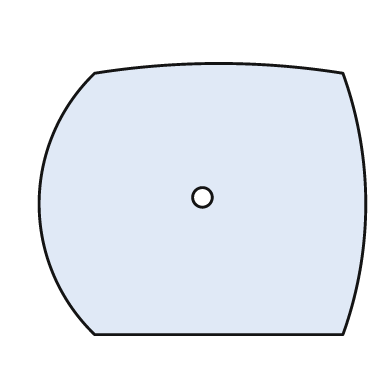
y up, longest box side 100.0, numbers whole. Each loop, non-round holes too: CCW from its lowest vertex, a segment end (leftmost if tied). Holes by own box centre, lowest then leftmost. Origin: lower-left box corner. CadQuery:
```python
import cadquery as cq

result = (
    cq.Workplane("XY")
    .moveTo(17.0, 0.0)
    .lineTo(93.0, 0.0)
    .threePointArc((100.0, 40.0), (93.0, 80.0))
    .threePointArc((55.0, 83.0), (17.0, 80.0))
    .threePointArc((0.0, 40.0), (17.0, 0.0))
    .close()
    .moveTo(50.0, 42.0)
    .circle(3.0)
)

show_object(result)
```